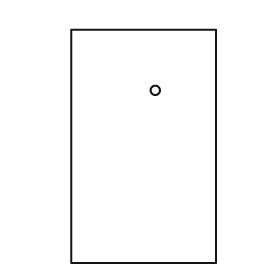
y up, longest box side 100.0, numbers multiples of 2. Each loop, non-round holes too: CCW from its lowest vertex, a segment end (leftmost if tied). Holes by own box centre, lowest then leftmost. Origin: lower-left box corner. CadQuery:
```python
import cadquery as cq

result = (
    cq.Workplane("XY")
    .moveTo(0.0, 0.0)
    .lineTo(62.0, 0.0)
    .lineTo(62.0, 100.0)
    .lineTo(0.0, 100.0)
    .close()
    .moveTo(36.0, 74.0)
    .circle(2.0)
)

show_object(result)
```